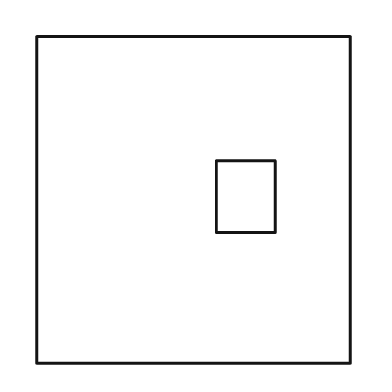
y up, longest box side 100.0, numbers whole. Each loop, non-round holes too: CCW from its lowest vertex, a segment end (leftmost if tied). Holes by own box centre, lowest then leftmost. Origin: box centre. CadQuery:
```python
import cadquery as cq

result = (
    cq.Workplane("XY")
    .moveTo(-48.0, -50.0)
    .lineTo(48.0, -50.0)
    .lineTo(48.0, 50.0)
    .lineTo(-48.0, 50.0)
    .close()
    .moveTo(7.0, -10.0)
    .lineTo(25.0, -10.0)
    .lineTo(25.0, 12.0)
    .lineTo(7.0, 12.0)
    .close()
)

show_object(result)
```